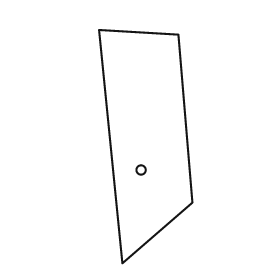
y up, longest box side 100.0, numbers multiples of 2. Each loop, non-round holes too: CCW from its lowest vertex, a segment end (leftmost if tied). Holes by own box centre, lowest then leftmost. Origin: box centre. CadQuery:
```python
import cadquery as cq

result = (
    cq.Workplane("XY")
    .moveTo(-10.0, -50.0)
    .lineTo(20.0, -24.0)
    .lineTo(14.0, 48.0)
    .lineTo(-20.0, 50.0)
    .close()
    .moveTo(-2.0, -10.0)
    .circle(2.0)
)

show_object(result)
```